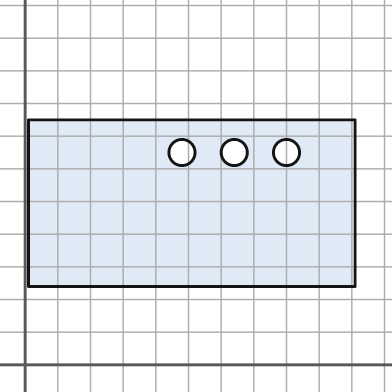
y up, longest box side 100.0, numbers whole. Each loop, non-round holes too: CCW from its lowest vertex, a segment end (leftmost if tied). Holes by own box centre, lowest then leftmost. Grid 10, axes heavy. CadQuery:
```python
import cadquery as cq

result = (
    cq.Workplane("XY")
    .moveTo(1.0, 24.0)
    .lineTo(101.0, 24.0)
    .lineTo(101.0, 75.0)
    .lineTo(1.0, 75.0)
    .close()
    .moveTo(48.0, 65.0)
    .circle(4.0)
    .moveTo(64.0, 65.0)
    .circle(4.0)
    .moveTo(80.0, 65.0)
    .circle(4.0)
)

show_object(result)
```